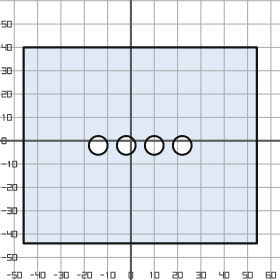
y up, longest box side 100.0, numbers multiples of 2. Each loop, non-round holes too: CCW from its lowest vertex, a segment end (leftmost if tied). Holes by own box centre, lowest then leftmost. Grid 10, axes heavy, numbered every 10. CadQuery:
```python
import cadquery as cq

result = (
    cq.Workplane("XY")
    .moveTo(-46.0, -44.0)
    .lineTo(54.0, -44.0)
    .lineTo(54.0, 40.0)
    .lineTo(-46.0, 40.0)
    .close()
    .moveTo(-14.0, -2.0)
    .circle(4.0)
    .moveTo(-2.0, -2.0)
    .circle(4.0)
    .moveTo(10.0, -2.0)
    .circle(4.0)
    .moveTo(22.0, -2.0)
    .circle(4.0)
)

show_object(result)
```